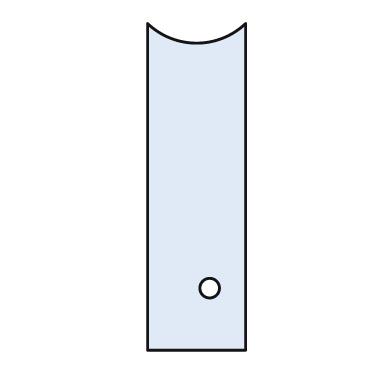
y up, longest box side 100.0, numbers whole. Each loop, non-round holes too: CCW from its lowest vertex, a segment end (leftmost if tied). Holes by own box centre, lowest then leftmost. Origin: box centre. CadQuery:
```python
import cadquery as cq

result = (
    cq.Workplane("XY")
    .moveTo(-15.0, -50.0)
    .lineTo(15.0, -50.0)
    .lineTo(15.0, 50.0)
    .threePointArc((0.0, 44.0), (-15.0, 50.0))
    .close()
    .moveTo(4.0, -31.0)
    .circle(3.0)
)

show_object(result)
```